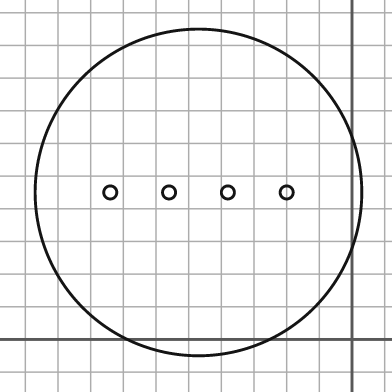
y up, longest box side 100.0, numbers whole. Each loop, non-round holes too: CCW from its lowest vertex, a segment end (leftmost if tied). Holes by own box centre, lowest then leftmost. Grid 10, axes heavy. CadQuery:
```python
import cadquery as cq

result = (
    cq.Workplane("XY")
    .moveTo(-47.0, 45.0)
    .circle(50.0)
    .moveTo(-74.0, 45.0)
    .circle(2.0)
    .moveTo(-56.0, 45.0)
    .circle(2.0)
    .moveTo(-38.0, 45.0)
    .circle(2.0)
    .moveTo(-20.0, 45.0)
    .circle(2.0)
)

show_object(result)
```